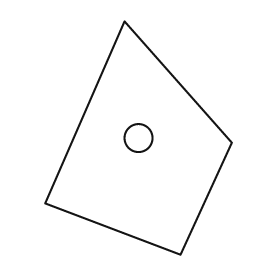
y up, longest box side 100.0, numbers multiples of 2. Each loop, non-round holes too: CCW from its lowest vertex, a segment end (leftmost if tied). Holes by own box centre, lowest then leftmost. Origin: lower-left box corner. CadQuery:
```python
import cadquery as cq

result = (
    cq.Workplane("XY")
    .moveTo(58.0, 0.0)
    .lineTo(80.0, 48.0)
    .lineTo(34.0, 100.0)
    .lineTo(0.0, 22.0)
    .close()
    .moveTo(40.0, 50.0)
    .circle(6.0)
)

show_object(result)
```